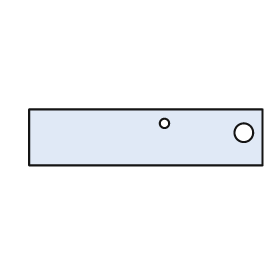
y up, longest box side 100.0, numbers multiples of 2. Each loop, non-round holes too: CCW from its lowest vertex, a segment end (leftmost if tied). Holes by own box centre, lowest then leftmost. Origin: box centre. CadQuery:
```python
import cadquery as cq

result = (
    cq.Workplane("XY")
    .moveTo(-50.0, -12.0)
    .lineTo(50.0, -12.0)
    .lineTo(50.0, 12.0)
    .lineTo(-50.0, 12.0)
    .close()
    .moveTo(42.0, 2.0)
    .circle(4.0)
    .moveTo(8.0, 6.0)
    .circle(2.0)
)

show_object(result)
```